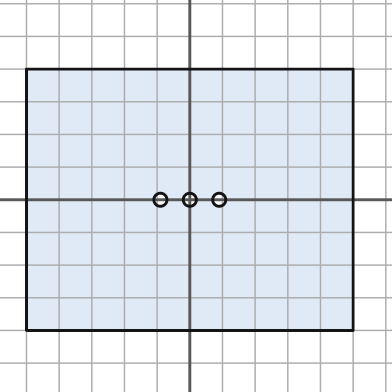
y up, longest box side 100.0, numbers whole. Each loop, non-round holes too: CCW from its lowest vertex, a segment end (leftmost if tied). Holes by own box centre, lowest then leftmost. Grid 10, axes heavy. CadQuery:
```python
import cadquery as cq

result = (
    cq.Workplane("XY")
    .moveTo(-50.0, -40.0)
    .lineTo(50.0, -40.0)
    .lineTo(50.0, 40.0)
    .lineTo(-50.0, 40.0)
    .close()
    .moveTo(-9.0, 0.0)
    .circle(2.0)
    .moveTo(0.0, 0.0)
    .circle(2.0)
    .moveTo(9.0, 0.0)
    .circle(2.0)
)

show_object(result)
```